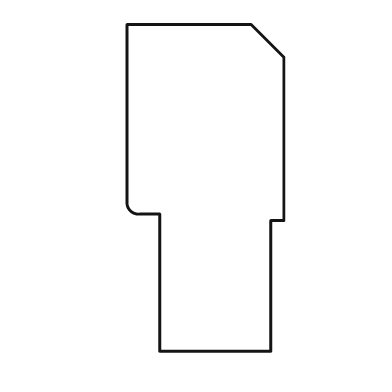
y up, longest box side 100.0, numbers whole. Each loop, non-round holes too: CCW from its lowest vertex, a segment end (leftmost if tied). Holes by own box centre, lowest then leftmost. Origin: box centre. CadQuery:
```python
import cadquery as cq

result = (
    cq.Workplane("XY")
    .moveTo(-14.0, -50.0)
    .lineTo(20.0, -50.0)
    .lineTo(20.0, -10.0)
    .lineTo(24.0, -10.0)
    .lineTo(24.0, 40.0)
    .lineTo(14.0, 50.0)
    .lineTo(-24.0, 50.0)
    .lineTo(-24.0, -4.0)
    .threePointArc((-23.0, -7.0), (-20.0, -8.0))
    .lineTo(-14.0, -8.0)
    .close()
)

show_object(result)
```